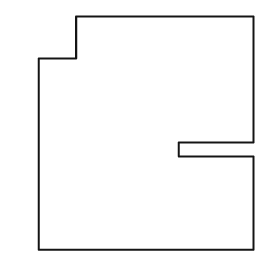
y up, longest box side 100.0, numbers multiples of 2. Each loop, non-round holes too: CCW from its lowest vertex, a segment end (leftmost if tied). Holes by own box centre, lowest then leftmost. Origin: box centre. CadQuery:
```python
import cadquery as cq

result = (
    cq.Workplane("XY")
    .moveTo(-46.0, -50.0)
    .lineTo(46.0, -50.0)
    .lineTo(46.0, -10.0)
    .lineTo(14.0, -10.0)
    .lineTo(14.0, -4.0)
    .lineTo(46.0, -4.0)
    .lineTo(46.0, 50.0)
    .lineTo(-30.0, 50.0)
    .lineTo(-30.0, 32.0)
    .lineTo(-46.0, 32.0)
    .close()
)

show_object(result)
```